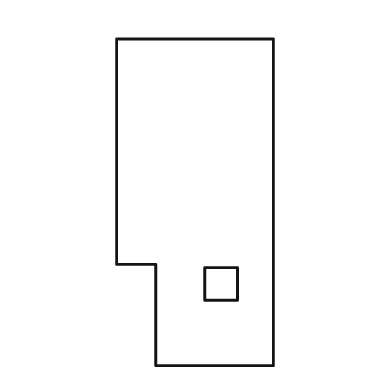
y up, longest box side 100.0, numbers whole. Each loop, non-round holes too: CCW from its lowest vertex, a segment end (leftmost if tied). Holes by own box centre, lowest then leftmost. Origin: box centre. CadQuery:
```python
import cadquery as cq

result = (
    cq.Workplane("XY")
    .moveTo(-12.0, -50.0)
    .lineTo(24.0, -50.0)
    .lineTo(24.0, 50.0)
    .lineTo(-24.0, 50.0)
    .lineTo(-24.0, -19.0)
    .lineTo(-12.0, -19.0)
    .close()
    .moveTo(3.0, -30.0)
    .lineTo(13.0, -30.0)
    .lineTo(13.0, -20.0)
    .lineTo(3.0, -20.0)
    .close()
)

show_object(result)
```